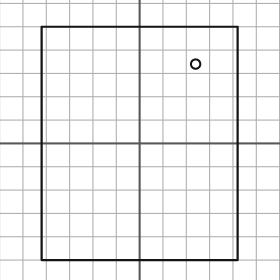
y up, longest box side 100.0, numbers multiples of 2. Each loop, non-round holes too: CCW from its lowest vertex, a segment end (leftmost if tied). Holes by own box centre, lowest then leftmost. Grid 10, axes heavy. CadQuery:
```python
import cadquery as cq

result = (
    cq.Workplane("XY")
    .moveTo(-42.0, -50.0)
    .lineTo(42.0, -50.0)
    .lineTo(42.0, 50.0)
    .lineTo(-42.0, 50.0)
    .close()
    .moveTo(24.0, 34.0)
    .circle(2.0)
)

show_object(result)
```